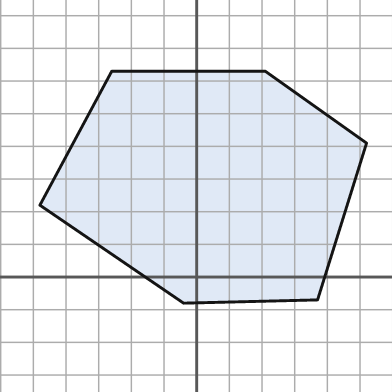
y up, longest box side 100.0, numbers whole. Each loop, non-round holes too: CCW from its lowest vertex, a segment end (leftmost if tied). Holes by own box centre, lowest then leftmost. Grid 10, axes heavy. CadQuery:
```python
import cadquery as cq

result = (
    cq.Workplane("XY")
    .moveTo(-4.0, -8.0)
    .lineTo(37.0, -7.0)
    .lineTo(52.0, 41.0)
    .lineTo(21.0, 63.0)
    .lineTo(-26.0, 63.0)
    .lineTo(-48.0, 22.0)
    .close()
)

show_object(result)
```